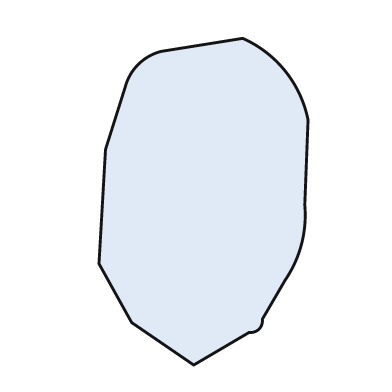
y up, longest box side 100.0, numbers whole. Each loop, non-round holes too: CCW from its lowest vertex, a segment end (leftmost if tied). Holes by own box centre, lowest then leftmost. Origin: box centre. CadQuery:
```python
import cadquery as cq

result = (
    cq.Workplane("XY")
    .moveTo(-3.0, -50.0)
    .lineTo(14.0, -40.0)
    .threePointArc((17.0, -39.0), (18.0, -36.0))
    .lineTo(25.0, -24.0)
    .threePointArc((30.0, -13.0), (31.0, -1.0))
    .lineTo(32.0, 25.0)
    .threePointArc((25.0, 40.0), (12.0, 50.0))
    .lineTo(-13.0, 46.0)
    .threePointArc((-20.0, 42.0), (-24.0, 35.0))
    .lineTo(-30.0, 16.0)
    .lineTo(-32.0, -19.0)
    .lineTo(-22.0, -37.0)
    .close()
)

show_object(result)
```